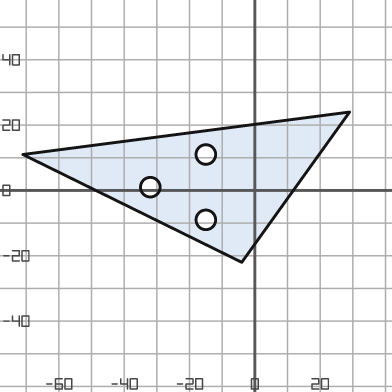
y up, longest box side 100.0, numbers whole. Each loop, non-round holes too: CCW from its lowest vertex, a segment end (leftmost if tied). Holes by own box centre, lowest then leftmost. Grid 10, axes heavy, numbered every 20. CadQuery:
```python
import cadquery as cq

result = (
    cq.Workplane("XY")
    .moveTo(-4.0, -22.0)
    .lineTo(29.0, 24.0)
    .lineTo(-71.0, 11.0)
    .close()
    .moveTo(-15.0, -9.0)
    .circle(3.0)
    .moveTo(-32.0, 1.0)
    .circle(3.0)
    .moveTo(-15.0, 11.0)
    .circle(3.0)
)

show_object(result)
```